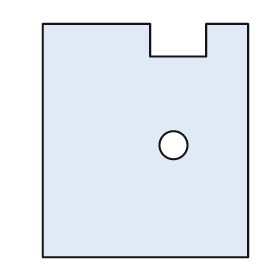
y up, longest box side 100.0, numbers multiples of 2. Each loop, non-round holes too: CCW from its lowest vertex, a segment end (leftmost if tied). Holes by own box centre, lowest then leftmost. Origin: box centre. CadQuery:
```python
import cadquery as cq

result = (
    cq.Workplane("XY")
    .moveTo(-44.0, -50.0)
    .lineTo(44.0, -50.0)
    .lineTo(44.0, 50.0)
    .lineTo(26.0, 50.0)
    .lineTo(26.0, 36.0)
    .lineTo(2.0, 36.0)
    .lineTo(2.0, 50.0)
    .lineTo(-44.0, 50.0)
    .close()
    .moveTo(12.0, -2.0)
    .circle(6.0)
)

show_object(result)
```